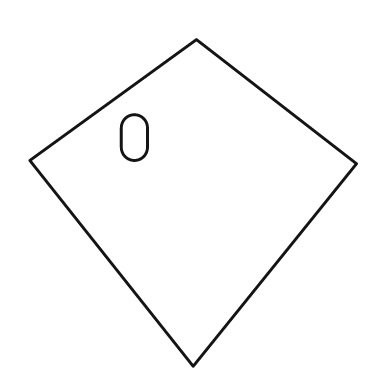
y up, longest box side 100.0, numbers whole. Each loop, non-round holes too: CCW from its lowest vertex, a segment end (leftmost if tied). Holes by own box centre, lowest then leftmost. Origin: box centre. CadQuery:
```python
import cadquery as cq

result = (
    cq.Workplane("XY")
    .moveTo(0.0, -50.0)
    .lineTo(50.0, 12.0)
    .lineTo(1.0, 50.0)
    .lineTo(-50.0, 13.0)
    .close()
    .moveTo(-22.0, 17.0)
    .threePointArc((-18.0, 13.0), (-14.0, 17.0))
    .lineTo(-14.0, 23.0)
    .threePointArc((-18.0, 27.0), (-22.0, 23.0))
    .close()
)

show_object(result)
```